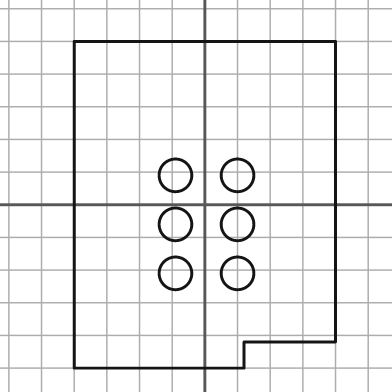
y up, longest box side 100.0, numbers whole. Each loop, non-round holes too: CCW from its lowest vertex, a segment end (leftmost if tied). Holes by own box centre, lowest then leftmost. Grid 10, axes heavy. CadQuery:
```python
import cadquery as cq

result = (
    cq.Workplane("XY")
    .moveTo(-40.0, -50.0)
    .lineTo(12.0, -50.0)
    .lineTo(12.0, -42.0)
    .lineTo(40.0, -42.0)
    .lineTo(40.0, 50.0)
    .lineTo(-40.0, 50.0)
    .close()
    .moveTo(-9.0, -21.0)
    .circle(5.0)
    .moveTo(10.0, -21.0)
    .circle(5.0)
    .moveTo(-9.0, -6.0)
    .circle(5.0)
    .moveTo(10.0, -6.0)
    .circle(5.0)
    .moveTo(-9.0, 9.0)
    .circle(5.0)
    .moveTo(10.0, 9.0)
    .circle(5.0)
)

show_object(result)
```